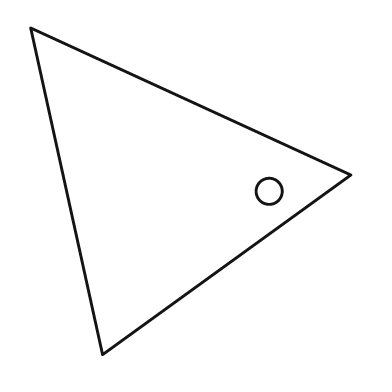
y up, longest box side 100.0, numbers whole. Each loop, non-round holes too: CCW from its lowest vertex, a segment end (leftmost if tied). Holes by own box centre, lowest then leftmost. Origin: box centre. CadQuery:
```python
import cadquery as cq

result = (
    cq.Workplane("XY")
    .moveTo(-27.0, -50.0)
    .lineTo(49.0, 5.0)
    .lineTo(-49.0, 50.0)
    .close()
    .moveTo(24.0, 0.0)
    .circle(4.0)
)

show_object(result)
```